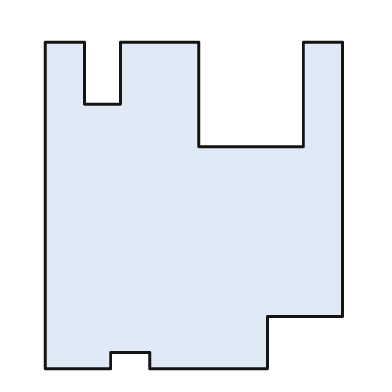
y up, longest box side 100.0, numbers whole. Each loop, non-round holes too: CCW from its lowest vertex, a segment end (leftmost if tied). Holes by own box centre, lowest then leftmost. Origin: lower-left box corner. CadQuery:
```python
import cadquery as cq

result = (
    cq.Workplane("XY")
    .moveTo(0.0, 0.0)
    .lineTo(20.0, 0.0)
    .lineTo(20.0, 5.0)
    .lineTo(32.0, 5.0)
    .lineTo(32.0, 0.0)
    .lineTo(68.0, 0.0)
    .lineTo(68.0, 16.0)
    .lineTo(91.0, 16.0)
    .lineTo(91.0, 100.0)
    .lineTo(79.0, 100.0)
    .lineTo(79.0, 68.0)
    .lineTo(47.0, 68.0)
    .lineTo(47.0, 100.0)
    .lineTo(23.0, 100.0)
    .lineTo(23.0, 81.0)
    .lineTo(12.0, 81.0)
    .lineTo(12.0, 100.0)
    .lineTo(0.0, 100.0)
    .close()
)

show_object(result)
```